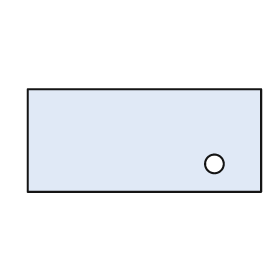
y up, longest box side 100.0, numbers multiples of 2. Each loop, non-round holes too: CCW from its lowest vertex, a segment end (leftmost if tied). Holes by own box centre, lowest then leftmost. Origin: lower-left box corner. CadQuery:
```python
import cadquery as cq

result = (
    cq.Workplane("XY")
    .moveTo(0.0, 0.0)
    .lineTo(100.0, 0.0)
    .lineTo(100.0, 44.0)
    .lineTo(0.0, 44.0)
    .close()
    .moveTo(80.0, 12.0)
    .circle(4.0)
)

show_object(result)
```